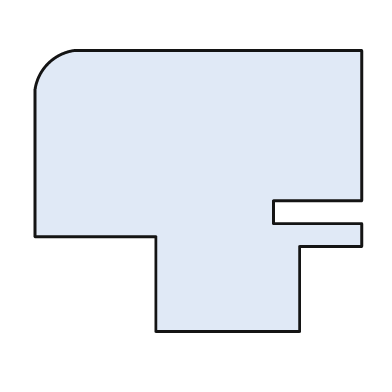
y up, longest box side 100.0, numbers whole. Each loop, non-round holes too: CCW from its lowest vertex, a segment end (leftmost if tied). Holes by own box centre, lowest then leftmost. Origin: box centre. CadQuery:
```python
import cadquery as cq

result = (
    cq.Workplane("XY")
    .moveTo(-13.0, -43.0)
    .lineTo(31.0, -43.0)
    .lineTo(31.0, -17.0)
    .lineTo(50.0, -17.0)
    .lineTo(50.0, -10.0)
    .lineTo(23.0, -10.0)
    .lineTo(23.0, -3.0)
    .lineTo(50.0, -3.0)
    .lineTo(50.0, 43.0)
    .lineTo(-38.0, 43.0)
    .threePointArc((-46.0, 39.0), (-50.0, 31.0))
    .lineTo(-50.0, -14.0)
    .lineTo(-13.0, -14.0)
    .close()
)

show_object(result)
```